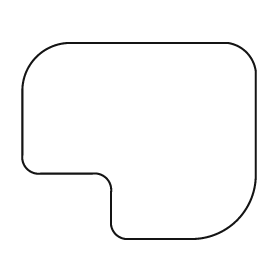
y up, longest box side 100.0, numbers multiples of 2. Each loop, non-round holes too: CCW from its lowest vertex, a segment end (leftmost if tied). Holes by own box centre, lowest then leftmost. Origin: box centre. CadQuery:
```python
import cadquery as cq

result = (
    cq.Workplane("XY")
    .moveTo(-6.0, -42.0)
    .lineTo(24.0, -42.0)
    .threePointArc((42.0, -34.0), (50.0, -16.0))
    .lineTo(50.0, 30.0)
    .threePointArc((46.0, 38.0), (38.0, 42.0))
    .lineTo(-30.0, 42.0)
    .threePointArc((-44.0, 36.0), (-50.0, 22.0))
    .lineTo(-50.0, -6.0)
    .threePointArc((-48.0, -12.0), (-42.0, -14.0))
    .lineTo(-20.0, -14.0)
    .threePointArc((-14.0, -16.0), (-12.0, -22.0))
    .lineTo(-12.0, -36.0)
    .threePointArc((-10.0, -40.0), (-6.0, -42.0))
    .close()
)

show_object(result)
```